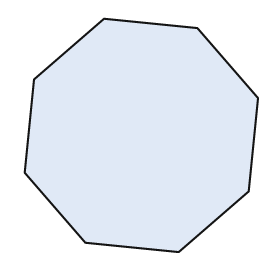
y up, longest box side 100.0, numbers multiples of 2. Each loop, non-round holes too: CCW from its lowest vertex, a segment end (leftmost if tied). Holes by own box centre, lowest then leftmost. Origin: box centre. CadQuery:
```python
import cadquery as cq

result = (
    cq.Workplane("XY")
    .moveTo(16.0, -50.0)
    .lineTo(46.0, -24.0)
    .lineTo(50.0, 16.0)
    .lineTo(24.0, 46.0)
    .lineTo(-16.0, 50.0)
    .lineTo(-46.0, 24.0)
    .lineTo(-50.0, -16.0)
    .lineTo(-24.0, -46.0)
    .close()
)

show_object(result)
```